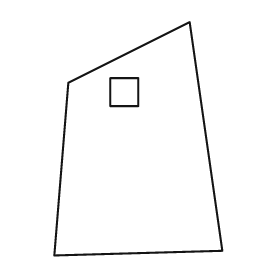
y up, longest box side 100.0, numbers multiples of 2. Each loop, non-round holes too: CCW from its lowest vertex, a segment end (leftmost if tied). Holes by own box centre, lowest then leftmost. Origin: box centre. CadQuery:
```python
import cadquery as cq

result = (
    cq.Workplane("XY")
    .moveTo(-36.0, -50.0)
    .lineTo(36.0, -48.0)
    .lineTo(22.0, 50.0)
    .lineTo(-30.0, 24.0)
    .close()
    .moveTo(-12.0, 14.0)
    .lineTo(0.0, 14.0)
    .lineTo(0.0, 26.0)
    .lineTo(-12.0, 26.0)
    .close()
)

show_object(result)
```